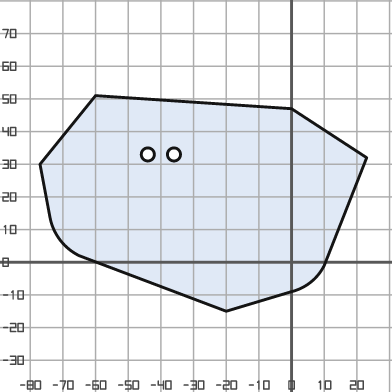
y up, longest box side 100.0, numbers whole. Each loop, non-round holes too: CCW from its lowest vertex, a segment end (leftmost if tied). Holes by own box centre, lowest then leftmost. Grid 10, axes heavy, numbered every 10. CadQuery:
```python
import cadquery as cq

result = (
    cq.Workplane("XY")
    .moveTo(-20.0, -15.0)
    .lineTo(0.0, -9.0)
    .threePointArc((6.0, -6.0), (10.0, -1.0))
    .lineTo(23.0, 32.0)
    .lineTo(0.0, 47.0)
    .lineTo(-60.0, 51.0)
    .lineTo(-77.0, 30.0)
    .lineTo(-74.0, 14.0)
    .threePointArc((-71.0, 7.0), (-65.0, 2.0))
    .close()
    .moveTo(-44.0, 33.0)
    .circle(2.0)
    .moveTo(-36.0, 33.0)
    .circle(2.0)
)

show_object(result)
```